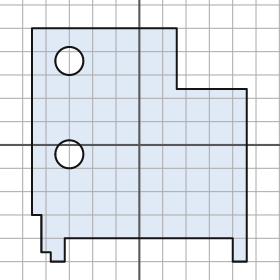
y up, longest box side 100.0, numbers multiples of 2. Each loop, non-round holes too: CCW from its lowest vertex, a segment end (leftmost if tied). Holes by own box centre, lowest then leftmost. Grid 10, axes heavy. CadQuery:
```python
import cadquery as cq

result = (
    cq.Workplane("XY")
    .moveTo(-38.0, -50.0)
    .lineTo(-32.0, -50.0)
    .lineTo(-32.0, -40.0)
    .lineTo(40.0, -40.0)
    .lineTo(40.0, -50.0)
    .lineTo(46.0, -50.0)
    .lineTo(46.0, 24.0)
    .lineTo(16.0, 24.0)
    .lineTo(16.0, 50.0)
    .lineTo(-46.0, 50.0)
    .lineTo(-46.0, -30.0)
    .lineTo(-42.0, -30.0)
    .lineTo(-42.0, -46.0)
    .lineTo(-38.0, -46.0)
    .close()
    .moveTo(-30.0, -4.0)
    .circle(6.0)
    .moveTo(-30.0, 36.0)
    .circle(6.0)
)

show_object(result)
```